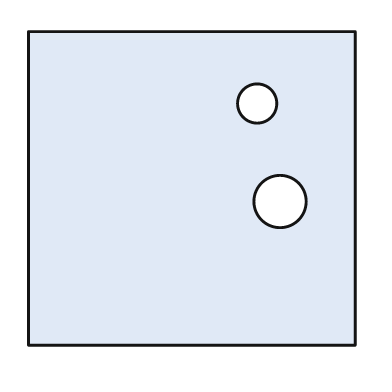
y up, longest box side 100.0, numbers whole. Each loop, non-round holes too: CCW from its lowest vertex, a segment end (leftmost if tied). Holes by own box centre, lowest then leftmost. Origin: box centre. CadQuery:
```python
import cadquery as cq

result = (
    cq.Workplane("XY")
    .moveTo(-50.0, -48.0)
    .lineTo(50.0, -48.0)
    .lineTo(50.0, 48.0)
    .lineTo(-50.0, 48.0)
    .close()
    .moveTo(27.0, -4.0)
    .circle(8.0)
    .moveTo(20.0, 26.0)
    .circle(6.0)
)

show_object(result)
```